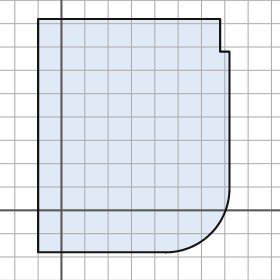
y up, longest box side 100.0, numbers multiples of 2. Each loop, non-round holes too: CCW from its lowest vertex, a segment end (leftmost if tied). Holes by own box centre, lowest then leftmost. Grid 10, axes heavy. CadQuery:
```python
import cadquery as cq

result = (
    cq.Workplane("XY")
    .moveTo(-10.0, -18.0)
    .lineTo(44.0, -18.0)
    .threePointArc((64.0, -10.0), (72.0, 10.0))
    .lineTo(72.0, 68.0)
    .lineTo(68.0, 68.0)
    .lineTo(68.0, 82.0)
    .lineTo(-10.0, 82.0)
    .close()
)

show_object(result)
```